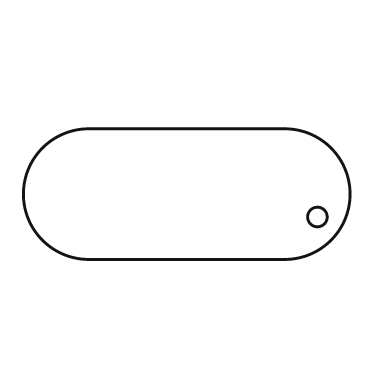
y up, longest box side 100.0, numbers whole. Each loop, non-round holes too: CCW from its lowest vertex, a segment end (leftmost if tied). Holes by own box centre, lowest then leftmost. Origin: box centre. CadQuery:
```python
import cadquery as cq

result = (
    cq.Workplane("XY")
    .moveTo(-30.0, -20.0)
    .lineTo(30.0, -20.0)
    .threePointArc((50.0, 0.0), (30.0, 20.0))
    .lineTo(-30.0, 20.0)
    .threePointArc((-50.0, 0.0), (-30.0, -20.0))
    .close()
    .moveTo(40.0, -7.0)
    .circle(3.0)
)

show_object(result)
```